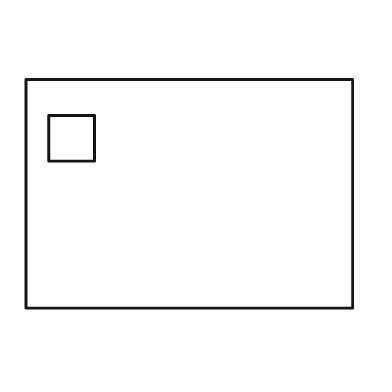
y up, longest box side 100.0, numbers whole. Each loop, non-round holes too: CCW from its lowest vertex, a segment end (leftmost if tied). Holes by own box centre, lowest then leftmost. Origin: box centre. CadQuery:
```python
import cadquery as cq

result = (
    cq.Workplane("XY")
    .moveTo(-50.0, -35.0)
    .lineTo(50.0, -35.0)
    .lineTo(50.0, 35.0)
    .lineTo(-50.0, 35.0)
    .close()
    .moveTo(-43.0, 10.0)
    .lineTo(-29.0, 10.0)
    .lineTo(-29.0, 24.0)
    .lineTo(-43.0, 24.0)
    .close()
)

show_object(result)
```